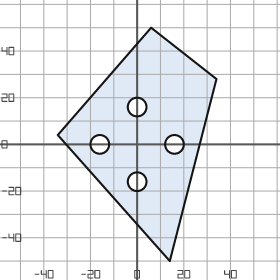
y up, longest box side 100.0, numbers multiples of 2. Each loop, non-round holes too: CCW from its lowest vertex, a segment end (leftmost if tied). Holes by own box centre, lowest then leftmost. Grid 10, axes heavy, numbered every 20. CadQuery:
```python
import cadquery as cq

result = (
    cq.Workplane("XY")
    .moveTo(14.0, -50.0)
    .lineTo(34.0, 28.0)
    .lineTo(6.0, 50.0)
    .lineTo(-34.0, 4.0)
    .close()
    .moveTo(0.0, -16.0)
    .circle(4.0)
    .moveTo(-16.0, 0.0)
    .circle(4.0)
    .moveTo(16.0, 0.0)
    .circle(4.0)
    .moveTo(0.0, 16.0)
    .circle(4.0)
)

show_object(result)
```